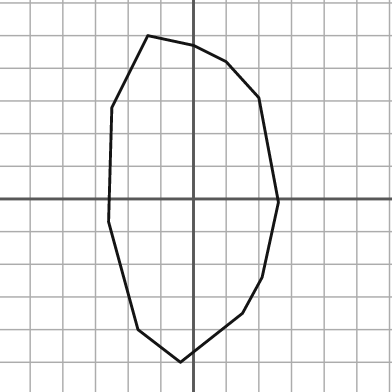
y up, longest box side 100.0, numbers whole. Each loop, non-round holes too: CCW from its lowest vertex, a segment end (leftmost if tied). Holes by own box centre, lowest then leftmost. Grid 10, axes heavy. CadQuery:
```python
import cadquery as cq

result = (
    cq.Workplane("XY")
    .moveTo(-4.0, -50.0)
    .lineTo(15.0, -35.0)
    .lineTo(21.0, -24.0)
    .lineTo(26.0, -1.0)
    .lineTo(20.0, 31.0)
    .lineTo(10.0, 42.0)
    .lineTo(0.0, 47.0)
    .lineTo(-14.0, 50.0)
    .lineTo(-25.0, 28.0)
    .lineTo(-26.0, -7.0)
    .lineTo(-17.0, -40.0)
    .close()
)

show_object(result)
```